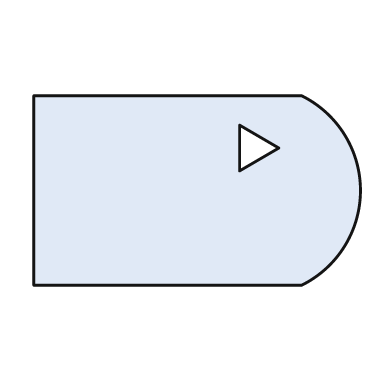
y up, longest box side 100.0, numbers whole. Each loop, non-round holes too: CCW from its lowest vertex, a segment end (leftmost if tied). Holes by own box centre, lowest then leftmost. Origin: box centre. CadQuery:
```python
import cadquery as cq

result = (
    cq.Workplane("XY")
    .moveTo(-50.0, -29.0)
    .lineTo(32.0, -29.0)
    .threePointArc((50.0, 0.0), (32.0, 29.0))
    .lineTo(-50.0, 29.0)
    .close()
    .moveTo(13.0, 6.0)
    .lineTo(25.0, 13.0)
    .lineTo(13.0, 20.0)
    .close()
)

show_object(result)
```